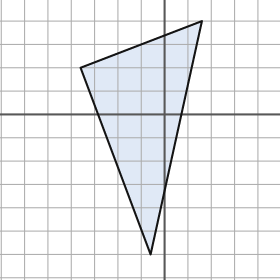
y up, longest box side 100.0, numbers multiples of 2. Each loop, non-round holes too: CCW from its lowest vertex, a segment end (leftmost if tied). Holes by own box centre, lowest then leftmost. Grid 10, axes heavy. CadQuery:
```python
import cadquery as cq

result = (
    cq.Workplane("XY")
    .moveTo(-6.0, -60.0)
    .lineTo(16.0, 40.0)
    .lineTo(-36.0, 20.0)
    .close()
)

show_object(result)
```